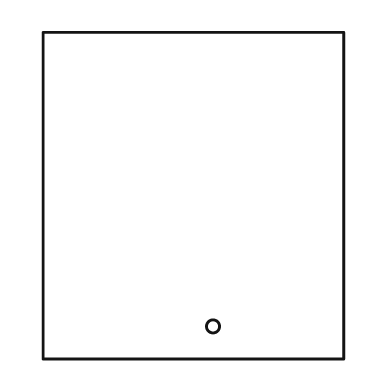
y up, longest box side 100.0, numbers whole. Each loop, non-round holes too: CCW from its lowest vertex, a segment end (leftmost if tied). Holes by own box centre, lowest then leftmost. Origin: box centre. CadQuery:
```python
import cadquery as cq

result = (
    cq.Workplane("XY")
    .moveTo(-46.0, -50.0)
    .lineTo(46.0, -50.0)
    .lineTo(46.0, 50.0)
    .lineTo(-46.0, 50.0)
    .close()
    .moveTo(6.0, -40.0)
    .circle(2.0)
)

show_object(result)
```